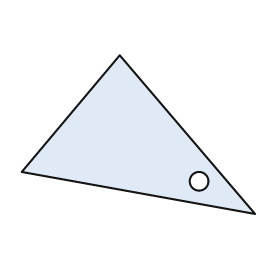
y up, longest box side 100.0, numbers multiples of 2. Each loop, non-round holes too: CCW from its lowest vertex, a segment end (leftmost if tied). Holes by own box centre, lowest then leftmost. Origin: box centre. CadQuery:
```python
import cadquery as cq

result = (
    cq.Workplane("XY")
    .moveTo(50.0, -34.0)
    .lineTo(-8.0, 34.0)
    .lineTo(-50.0, -16.0)
    .close()
    .moveTo(26.0, -20.0)
    .circle(4.0)
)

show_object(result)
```